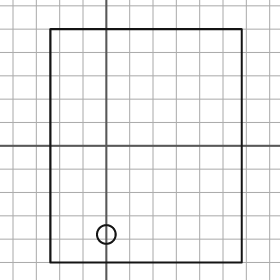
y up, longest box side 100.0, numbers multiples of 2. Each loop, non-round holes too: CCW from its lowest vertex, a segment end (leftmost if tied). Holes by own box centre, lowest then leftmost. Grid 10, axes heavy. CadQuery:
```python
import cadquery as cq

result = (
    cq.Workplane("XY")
    .moveTo(-24.0, -50.0)
    .lineTo(58.0, -50.0)
    .lineTo(58.0, 50.0)
    .lineTo(-24.0, 50.0)
    .close()
    .moveTo(0.0, -38.0)
    .circle(4.0)
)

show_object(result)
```